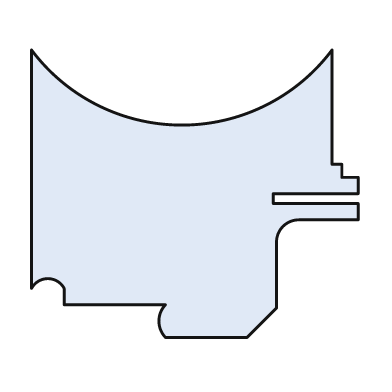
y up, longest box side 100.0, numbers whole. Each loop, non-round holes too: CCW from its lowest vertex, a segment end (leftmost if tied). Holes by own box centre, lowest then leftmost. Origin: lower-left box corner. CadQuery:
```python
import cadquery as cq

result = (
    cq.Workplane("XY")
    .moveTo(41.0, 0.0)
    .lineTo(66.0, 0.0)
    .lineTo(75.0, 9.0)
    .lineTo(75.0, 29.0)
    .threePointArc((77.0, 34.0), (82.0, 36.0))
    .lineTo(100.0, 36.0)
    .lineTo(100.0, 41.0)
    .lineTo(74.0, 41.0)
    .lineTo(74.0, 44.0)
    .lineTo(100.0, 44.0)
    .lineTo(100.0, 49.0)
    .lineTo(95.0, 49.0)
    .lineTo(95.0, 53.0)
    .lineTo(92.0, 53.0)
    .lineTo(92.0, 88.0)
    .threePointArc((46.0, 65.0), (0.0, 88.0))
    .lineTo(0.0, 15.0)
    .threePointArc((5.0, 18.0), (10.0, 15.0))
    .lineTo(10.0, 10.0)
    .lineTo(41.0, 10.0)
    .threePointArc((39.0, 5.0), (41.0, 0.0))
    .close()
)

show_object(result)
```